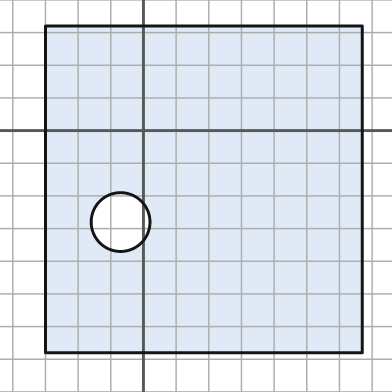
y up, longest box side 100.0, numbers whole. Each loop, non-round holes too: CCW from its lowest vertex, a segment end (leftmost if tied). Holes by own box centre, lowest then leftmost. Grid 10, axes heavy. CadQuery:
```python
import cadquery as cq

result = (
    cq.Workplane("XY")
    .moveTo(-30.0, -68.0)
    .lineTo(67.0, -68.0)
    .lineTo(67.0, 32.0)
    .lineTo(-30.0, 32.0)
    .close()
    .moveTo(-7.0, -28.0)
    .circle(9.0)
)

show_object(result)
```